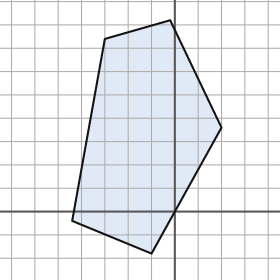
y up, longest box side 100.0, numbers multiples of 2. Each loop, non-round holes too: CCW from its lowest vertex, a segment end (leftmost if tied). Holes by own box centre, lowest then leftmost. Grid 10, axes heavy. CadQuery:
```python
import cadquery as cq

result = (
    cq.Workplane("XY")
    .moveTo(-10.0, -18.0)
    .lineTo(20.0, 36.0)
    .lineTo(-2.0, 82.0)
    .lineTo(-30.0, 74.0)
    .lineTo(-44.0, -4.0)
    .close()
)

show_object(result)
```